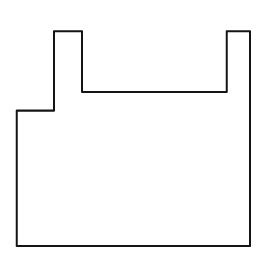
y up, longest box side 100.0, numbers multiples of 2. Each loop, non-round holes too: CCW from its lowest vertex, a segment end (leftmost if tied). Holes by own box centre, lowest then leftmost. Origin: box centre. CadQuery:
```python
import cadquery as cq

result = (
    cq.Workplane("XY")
    .moveTo(-50.0, -46.0)
    .lineTo(50.0, -46.0)
    .lineTo(50.0, 46.0)
    .lineTo(40.0, 46.0)
    .lineTo(40.0, 20.0)
    .lineTo(-22.0, 20.0)
    .lineTo(-22.0, 46.0)
    .lineTo(-34.0, 46.0)
    .lineTo(-34.0, 12.0)
    .lineTo(-50.0, 12.0)
    .close()
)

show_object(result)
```